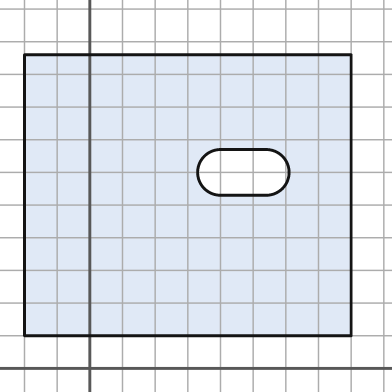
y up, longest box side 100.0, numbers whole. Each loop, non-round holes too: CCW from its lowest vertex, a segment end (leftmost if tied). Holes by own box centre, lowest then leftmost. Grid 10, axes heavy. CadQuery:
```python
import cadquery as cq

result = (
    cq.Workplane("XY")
    .moveTo(-20.0, 10.0)
    .lineTo(80.0, 10.0)
    .lineTo(80.0, 96.0)
    .lineTo(-20.0, 96.0)
    .close()
    .moveTo(40.0, 53.0)
    .lineTo(54.0, 53.0)
    .threePointArc((61.0, 60.0), (54.0, 67.0))
    .lineTo(40.0, 67.0)
    .threePointArc((33.0, 60.0), (40.0, 53.0))
    .close()
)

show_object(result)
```